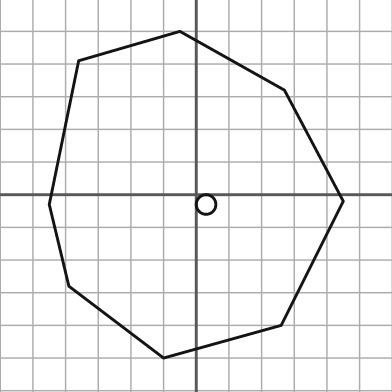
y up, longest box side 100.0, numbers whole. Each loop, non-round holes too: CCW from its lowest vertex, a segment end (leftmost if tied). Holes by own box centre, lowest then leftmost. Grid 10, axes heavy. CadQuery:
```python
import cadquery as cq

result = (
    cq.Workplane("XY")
    .moveTo(-10.0, -50.0)
    .lineTo(26.0, -40.0)
    .lineTo(45.0, -2.0)
    .lineTo(27.0, 32.0)
    .lineTo(-5.0, 50.0)
    .lineTo(-36.0, 41.0)
    .lineTo(-45.0, -3.0)
    .lineTo(-39.0, -28.0)
    .close()
    .moveTo(3.0, -3.0)
    .circle(3.0)
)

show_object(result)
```